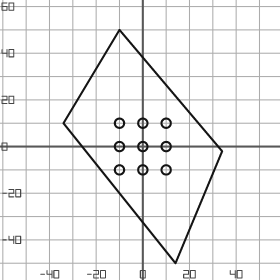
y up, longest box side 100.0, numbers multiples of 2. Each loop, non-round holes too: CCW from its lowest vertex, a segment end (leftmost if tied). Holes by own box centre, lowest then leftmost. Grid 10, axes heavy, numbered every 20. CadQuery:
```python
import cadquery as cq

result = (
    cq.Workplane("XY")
    .moveTo(14.0, -50.0)
    .lineTo(34.0, -2.0)
    .lineTo(-10.0, 50.0)
    .lineTo(-34.0, 10.0)
    .close()
    .moveTo(-10.0, -10.0)
    .circle(2.0)
    .moveTo(0.0, -10.0)
    .circle(2.0)
    .moveTo(10.0, -10.0)
    .circle(2.0)
    .moveTo(-10.0, 0.0)
    .circle(2.0)
    .moveTo(0.0, 0.0)
    .circle(2.0)
    .moveTo(10.0, 0.0)
    .circle(2.0)
    .moveTo(-10.0, 10.0)
    .circle(2.0)
    .moveTo(0.0, 10.0)
    .circle(2.0)
    .moveTo(10.0, 10.0)
    .circle(2.0)
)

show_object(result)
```